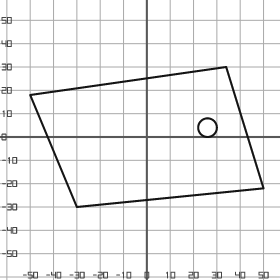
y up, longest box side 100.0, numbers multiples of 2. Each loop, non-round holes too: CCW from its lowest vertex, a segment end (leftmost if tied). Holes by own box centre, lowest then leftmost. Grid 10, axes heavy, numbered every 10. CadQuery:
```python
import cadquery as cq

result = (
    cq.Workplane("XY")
    .moveTo(-30.0, -30.0)
    .lineTo(50.0, -22.0)
    .lineTo(34.0, 30.0)
    .lineTo(-50.0, 18.0)
    .close()
    .moveTo(26.0, 4.0)
    .circle(4.0)
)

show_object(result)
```